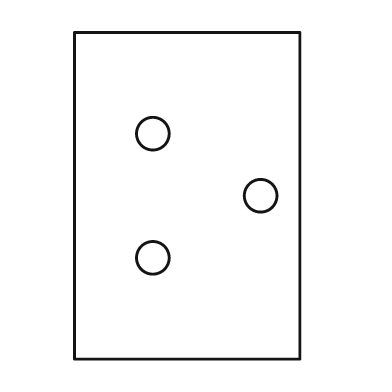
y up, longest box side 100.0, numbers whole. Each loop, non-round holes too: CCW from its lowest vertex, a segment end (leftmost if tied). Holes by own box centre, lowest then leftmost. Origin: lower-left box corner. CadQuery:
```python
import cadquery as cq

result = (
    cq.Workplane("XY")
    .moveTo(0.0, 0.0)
    .lineTo(69.0, 0.0)
    .lineTo(69.0, 100.0)
    .lineTo(0.0, 100.0)
    .close()
    .moveTo(24.0, 31.0)
    .circle(5.0)
    .moveTo(57.0, 50.0)
    .circle(5.0)
    .moveTo(24.0, 69.0)
    .circle(5.0)
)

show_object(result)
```